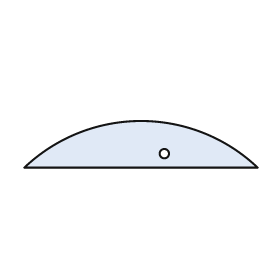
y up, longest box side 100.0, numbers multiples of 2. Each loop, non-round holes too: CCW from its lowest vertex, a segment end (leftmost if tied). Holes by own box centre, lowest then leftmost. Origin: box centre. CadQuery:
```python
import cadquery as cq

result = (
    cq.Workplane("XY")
    .moveTo(-50.0, -10.0)
    .lineTo(50.0, -10.0)
    .threePointArc((0.0, 10.0), (-50.0, -10.0))
    .close()
    .moveTo(10.0, -4.0)
    .circle(2.0)
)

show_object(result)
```